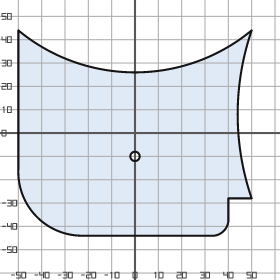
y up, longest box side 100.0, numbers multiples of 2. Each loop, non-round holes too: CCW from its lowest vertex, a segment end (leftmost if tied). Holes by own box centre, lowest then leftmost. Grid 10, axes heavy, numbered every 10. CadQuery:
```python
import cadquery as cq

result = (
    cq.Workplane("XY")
    .moveTo(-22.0, -44.0)
    .lineTo(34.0, -44.0)
    .threePointArc((38.0, -42.0), (40.0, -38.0))
    .lineTo(40.0, -28.0)
    .lineTo(50.0, -28.0)
    .threePointArc((44.0, 8.0), (50.0, 44.0))
    .threePointArc((0.0, 26.0), (-50.0, 44.0))
    .lineTo(-50.0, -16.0)
    .threePointArc((-42.0, -36.0), (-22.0, -44.0))
    .close()
    .moveTo(0.0, -10.0)
    .circle(2.0)
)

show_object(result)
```